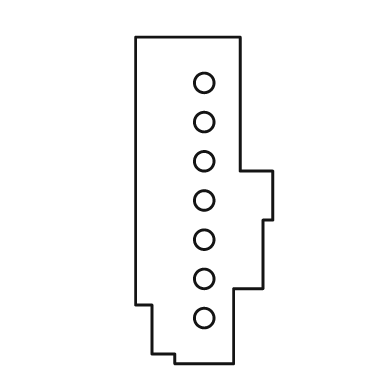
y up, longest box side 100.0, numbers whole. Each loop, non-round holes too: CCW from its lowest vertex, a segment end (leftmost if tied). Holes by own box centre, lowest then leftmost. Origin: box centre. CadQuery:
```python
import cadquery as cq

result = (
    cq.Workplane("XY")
    .moveTo(-9.0, -50.0)
    .lineTo(9.0, -50.0)
    .lineTo(9.0, -27.0)
    .lineTo(18.0, -27.0)
    .lineTo(18.0, -6.0)
    .lineTo(21.0, -6.0)
    .lineTo(21.0, 9.0)
    .lineTo(11.0, 9.0)
    .lineTo(11.0, 50.0)
    .lineTo(-21.0, 50.0)
    .lineTo(-21.0, -32.0)
    .lineTo(-16.0, -32.0)
    .lineTo(-16.0, -47.0)
    .lineTo(-9.0, -47.0)
    .close()
    .moveTo(0.0, -36.0)
    .circle(3.0)
    .moveTo(0.0, -24.0)
    .circle(3.0)
    .moveTo(0.0, -12.0)
    .circle(3.0)
    .moveTo(0.0, 0.0)
    .circle(3.0)
    .moveTo(0.0, 12.0)
    .circle(3.0)
    .moveTo(0.0, 24.0)
    .circle(3.0)
    .moveTo(0.0, 36.0)
    .circle(3.0)
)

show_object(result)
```